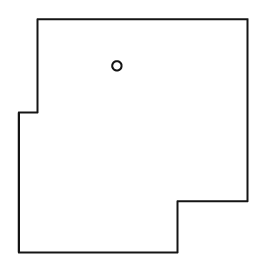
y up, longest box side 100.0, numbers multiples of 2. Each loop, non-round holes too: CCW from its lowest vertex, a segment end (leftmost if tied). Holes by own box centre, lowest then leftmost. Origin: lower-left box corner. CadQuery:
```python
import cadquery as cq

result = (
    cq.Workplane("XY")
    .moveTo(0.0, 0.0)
    .lineTo(68.0, 0.0)
    .lineTo(68.0, 22.0)
    .lineTo(98.0, 22.0)
    .lineTo(98.0, 100.0)
    .lineTo(8.0, 100.0)
    .lineTo(8.0, 60.0)
    .lineTo(0.0, 60.0)
    .close()
    .moveTo(42.0, 80.0)
    .circle(2.0)
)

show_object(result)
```